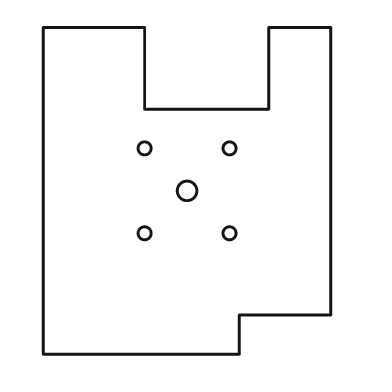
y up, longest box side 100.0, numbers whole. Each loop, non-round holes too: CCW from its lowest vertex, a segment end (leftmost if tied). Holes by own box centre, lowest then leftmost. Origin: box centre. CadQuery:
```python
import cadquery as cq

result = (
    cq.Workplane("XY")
    .moveTo(-44.0, -50.0)
    .lineTo(16.0, -50.0)
    .lineTo(16.0, -38.0)
    .lineTo(44.0, -38.0)
    .lineTo(44.0, 50.0)
    .lineTo(25.0, 50.0)
    .lineTo(25.0, 25.0)
    .lineTo(-13.0, 25.0)
    .lineTo(-13.0, 50.0)
    .lineTo(-44.0, 50.0)
    .close()
    .moveTo(-13.0, -13.0)
    .circle(2.0)
    .moveTo(13.0, -13.0)
    .circle(2.0)
    .moveTo(0.0, 0.0)
    .circle(3.0)
    .moveTo(-13.0, 13.0)
    .circle(2.0)
    .moveTo(13.0, 13.0)
    .circle(2.0)
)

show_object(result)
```